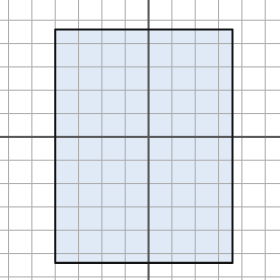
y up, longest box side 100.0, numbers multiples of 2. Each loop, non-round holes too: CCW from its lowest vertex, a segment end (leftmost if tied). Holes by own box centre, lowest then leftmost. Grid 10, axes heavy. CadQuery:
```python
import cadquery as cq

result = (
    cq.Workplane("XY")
    .moveTo(-40.0, -54.0)
    .lineTo(36.0, -54.0)
    .lineTo(36.0, 46.0)
    .lineTo(-40.0, 46.0)
    .close()
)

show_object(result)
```